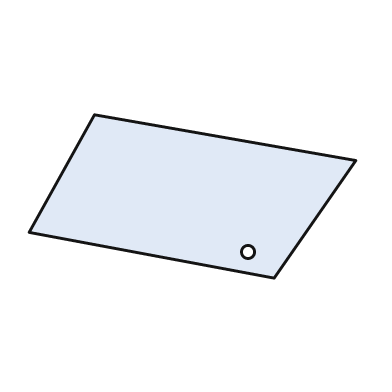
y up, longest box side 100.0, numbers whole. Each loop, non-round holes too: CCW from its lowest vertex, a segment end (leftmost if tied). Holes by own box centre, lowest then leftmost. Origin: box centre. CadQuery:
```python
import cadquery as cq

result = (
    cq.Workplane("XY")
    .moveTo(25.0, -25.0)
    .lineTo(50.0, 11.0)
    .lineTo(-30.0, 25.0)
    .lineTo(-50.0, -11.0)
    .close()
    .moveTo(17.0, -17.0)
    .circle(2.0)
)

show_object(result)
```